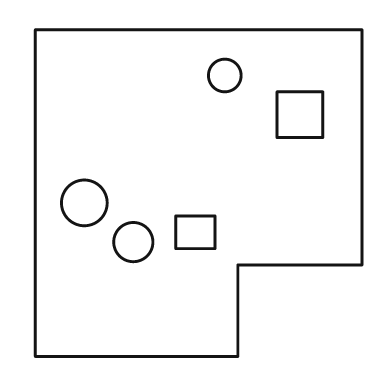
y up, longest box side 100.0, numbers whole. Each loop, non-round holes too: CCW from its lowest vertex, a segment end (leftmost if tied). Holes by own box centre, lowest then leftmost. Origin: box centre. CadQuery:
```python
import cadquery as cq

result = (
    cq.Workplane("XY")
    .moveTo(-50.0, -50.0)
    .lineTo(12.0, -50.0)
    .lineTo(12.0, -22.0)
    .lineTo(50.0, -22.0)
    .lineTo(50.0, 50.0)
    .lineTo(-50.0, 50.0)
    .close()
    .moveTo(-20.0, -15.0)
    .circle(6.0)
    .moveTo(-7.0, -17.0)
    .lineTo(5.0, -17.0)
    .lineTo(5.0, -7.0)
    .lineTo(-7.0, -7.0)
    .close()
    .moveTo(-35.0, -3.0)
    .circle(7.0)
    .moveTo(24.0, 17.0)
    .lineTo(38.0, 17.0)
    .lineTo(38.0, 31.0)
    .lineTo(24.0, 31.0)
    .close()
    .moveTo(8.0, 36.0)
    .circle(5.0)
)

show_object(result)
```